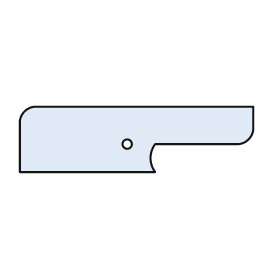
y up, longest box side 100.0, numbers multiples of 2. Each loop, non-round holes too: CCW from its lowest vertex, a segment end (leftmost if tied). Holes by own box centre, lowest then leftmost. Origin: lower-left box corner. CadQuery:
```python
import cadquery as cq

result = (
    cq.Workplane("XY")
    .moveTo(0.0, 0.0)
    .lineTo(58.0, 0.0)
    .threePointArc((56.0, 6.0), (58.0, 12.0))
    .lineTo(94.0, 12.0)
    .threePointArc((98.0, 14.0), (100.0, 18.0))
    .lineTo(100.0, 28.0)
    .lineTo(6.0, 28.0)
    .threePointArc((2.0, 26.0), (0.0, 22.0))
    .close()
    .moveTo(46.0, 12.0)
    .circle(2.0)
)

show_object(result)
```